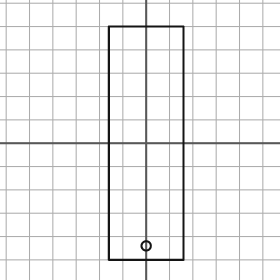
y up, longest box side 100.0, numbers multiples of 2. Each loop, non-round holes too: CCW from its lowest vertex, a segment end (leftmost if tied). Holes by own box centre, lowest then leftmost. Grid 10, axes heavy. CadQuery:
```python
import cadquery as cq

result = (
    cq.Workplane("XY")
    .moveTo(-16.0, -50.0)
    .lineTo(16.0, -50.0)
    .lineTo(16.0, 50.0)
    .lineTo(-16.0, 50.0)
    .close()
    .moveTo(0.0, -44.0)
    .circle(2.0)
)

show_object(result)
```